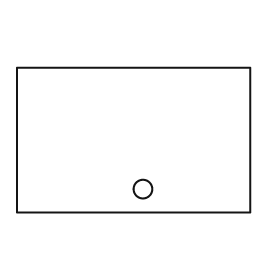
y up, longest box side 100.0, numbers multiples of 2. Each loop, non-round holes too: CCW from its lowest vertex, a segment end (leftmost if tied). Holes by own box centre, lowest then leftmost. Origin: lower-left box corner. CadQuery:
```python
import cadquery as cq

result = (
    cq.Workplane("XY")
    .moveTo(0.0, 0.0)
    .lineTo(100.0, 0.0)
    .lineTo(100.0, 62.0)
    .lineTo(0.0, 62.0)
    .close()
    .moveTo(54.0, 10.0)
    .circle(4.0)
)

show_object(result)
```